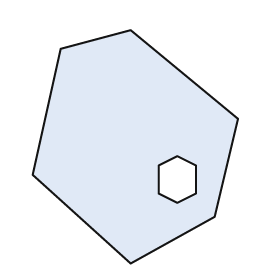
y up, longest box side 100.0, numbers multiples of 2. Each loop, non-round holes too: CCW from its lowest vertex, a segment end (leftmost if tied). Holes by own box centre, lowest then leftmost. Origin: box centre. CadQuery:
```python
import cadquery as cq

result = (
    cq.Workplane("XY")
    .moveTo(-2.0, -50.0)
    .lineTo(34.0, -30.0)
    .lineTo(44.0, 12.0)
    .lineTo(-2.0, 50.0)
    .lineTo(-32.0, 42.0)
    .lineTo(-44.0, -12.0)
    .close()
    .moveTo(18.0, -24.0)
    .lineTo(26.0, -20.0)
    .lineTo(26.0, -8.0)
    .lineTo(18.0, -4.0)
    .lineTo(10.0, -8.0)
    .lineTo(10.0, -20.0)
    .close()
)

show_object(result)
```